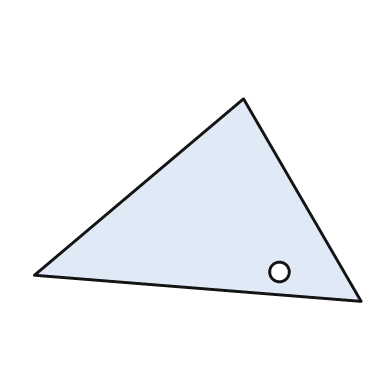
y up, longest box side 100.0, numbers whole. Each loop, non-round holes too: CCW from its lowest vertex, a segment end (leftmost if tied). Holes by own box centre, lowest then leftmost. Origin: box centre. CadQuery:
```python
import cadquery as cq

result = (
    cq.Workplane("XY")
    .moveTo(50.0, -31.0)
    .lineTo(14.0, 31.0)
    .lineTo(-50.0, -23.0)
    .close()
    .moveTo(25.0, -22.0)
    .circle(3.0)
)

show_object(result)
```